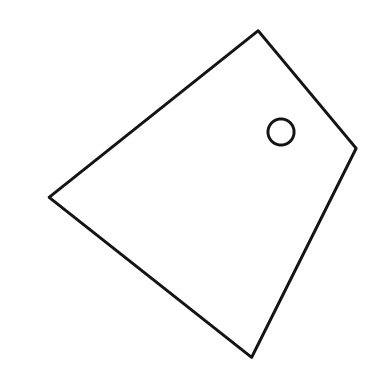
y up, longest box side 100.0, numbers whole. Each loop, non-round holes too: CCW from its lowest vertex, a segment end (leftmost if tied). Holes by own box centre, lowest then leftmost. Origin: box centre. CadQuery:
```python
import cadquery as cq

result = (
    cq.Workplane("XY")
    .moveTo(15.0, -50.0)
    .lineTo(47.0, 14.0)
    .lineTo(17.0, 50.0)
    .lineTo(-47.0, -1.0)
    .close()
    .moveTo(24.0, 19.0)
    .circle(4.0)
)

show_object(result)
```